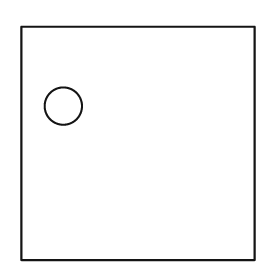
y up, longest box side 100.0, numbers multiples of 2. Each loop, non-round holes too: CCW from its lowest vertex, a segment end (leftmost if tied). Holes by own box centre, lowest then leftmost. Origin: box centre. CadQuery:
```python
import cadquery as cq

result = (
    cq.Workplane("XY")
    .moveTo(-50.0, -50.0)
    .lineTo(50.0, -50.0)
    .lineTo(50.0, 50.0)
    .lineTo(-50.0, 50.0)
    .close()
    .moveTo(-32.0, 16.0)
    .circle(8.0)
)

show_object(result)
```